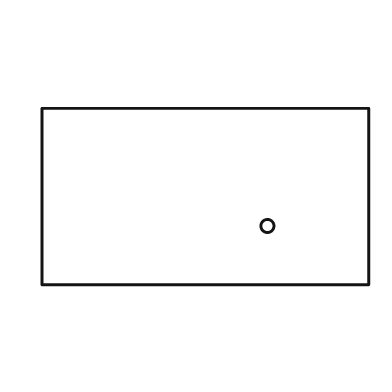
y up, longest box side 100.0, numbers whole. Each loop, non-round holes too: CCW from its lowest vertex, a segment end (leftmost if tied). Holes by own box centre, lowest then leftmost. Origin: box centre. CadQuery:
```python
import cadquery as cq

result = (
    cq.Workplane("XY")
    .moveTo(-50.0, -27.0)
    .lineTo(50.0, -27.0)
    .lineTo(50.0, 27.0)
    .lineTo(-50.0, 27.0)
    .close()
    .moveTo(19.0, -9.0)
    .circle(2.0)
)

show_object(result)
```